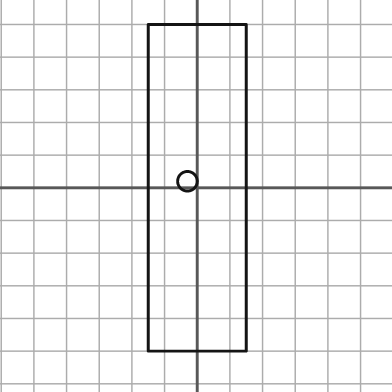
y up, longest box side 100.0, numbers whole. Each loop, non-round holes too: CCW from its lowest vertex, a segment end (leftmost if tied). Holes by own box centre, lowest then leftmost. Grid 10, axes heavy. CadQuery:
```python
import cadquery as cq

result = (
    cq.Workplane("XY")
    .moveTo(-15.0, -50.0)
    .lineTo(15.0, -50.0)
    .lineTo(15.0, 50.0)
    .lineTo(-15.0, 50.0)
    .close()
    .moveTo(-3.0, 2.0)
    .circle(3.0)
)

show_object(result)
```